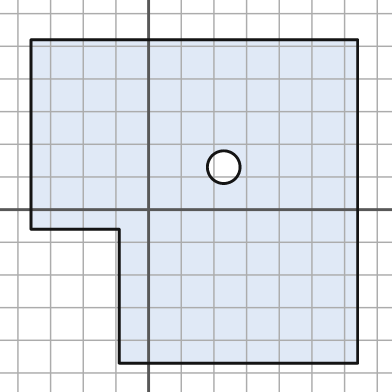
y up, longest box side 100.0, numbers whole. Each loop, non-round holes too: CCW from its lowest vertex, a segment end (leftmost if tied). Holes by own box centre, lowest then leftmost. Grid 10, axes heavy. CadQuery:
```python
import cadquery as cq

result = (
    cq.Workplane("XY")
    .moveTo(-9.0, -47.0)
    .lineTo(64.0, -47.0)
    .lineTo(64.0, 52.0)
    .lineTo(-36.0, 52.0)
    .lineTo(-36.0, -6.0)
    .lineTo(-9.0, -6.0)
    .close()
    .moveTo(23.0, 13.0)
    .circle(5.0)
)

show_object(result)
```